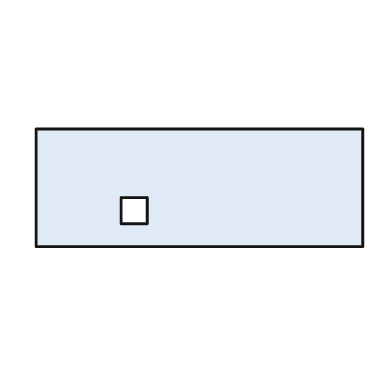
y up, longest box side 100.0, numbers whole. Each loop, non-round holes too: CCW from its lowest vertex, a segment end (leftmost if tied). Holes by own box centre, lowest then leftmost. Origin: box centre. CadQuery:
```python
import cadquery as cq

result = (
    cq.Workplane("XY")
    .moveTo(-50.0, -18.0)
    .lineTo(50.0, -18.0)
    .lineTo(50.0, 18.0)
    .lineTo(-50.0, 18.0)
    .close()
    .moveTo(-24.0, -11.0)
    .lineTo(-16.0, -11.0)
    .lineTo(-16.0, -3.0)
    .lineTo(-24.0, -3.0)
    .close()
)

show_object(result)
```